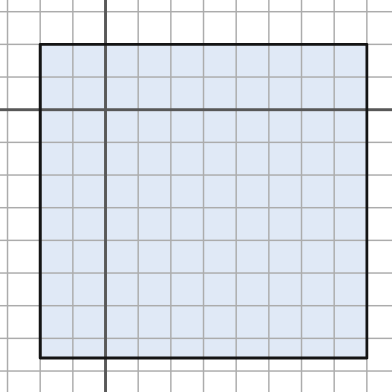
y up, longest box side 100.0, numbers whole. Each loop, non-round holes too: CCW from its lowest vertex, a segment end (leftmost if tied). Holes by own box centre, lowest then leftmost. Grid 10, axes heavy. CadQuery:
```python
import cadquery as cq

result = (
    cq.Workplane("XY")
    .moveTo(-20.0, -76.0)
    .lineTo(80.0, -76.0)
    .lineTo(80.0, 20.0)
    .lineTo(-20.0, 20.0)
    .close()
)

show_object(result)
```